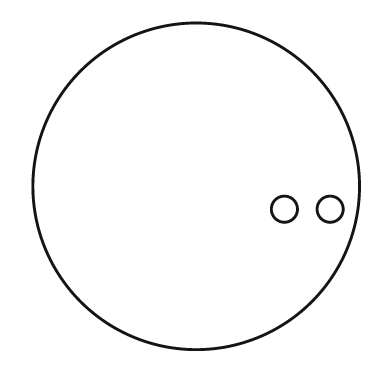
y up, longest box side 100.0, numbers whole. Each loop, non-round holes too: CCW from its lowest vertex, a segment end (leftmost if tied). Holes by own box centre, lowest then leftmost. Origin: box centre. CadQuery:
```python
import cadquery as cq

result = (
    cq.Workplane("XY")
    .moveTo(0.0, 0.0)
    .circle(50.0)
    .moveTo(27.0, -7.0)
    .circle(4.0)
    .moveTo(41.0, -7.0)
    .circle(4.0)
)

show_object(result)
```